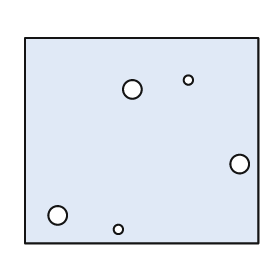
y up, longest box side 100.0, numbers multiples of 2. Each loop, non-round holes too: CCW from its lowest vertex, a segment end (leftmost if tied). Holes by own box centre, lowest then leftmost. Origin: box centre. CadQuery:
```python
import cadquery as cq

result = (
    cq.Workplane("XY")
    .moveTo(-50.0, -44.0)
    .lineTo(50.0, -44.0)
    .lineTo(50.0, 44.0)
    .lineTo(-50.0, 44.0)
    .close()
    .moveTo(-10.0, -38.0)
    .circle(2.0)
    .moveTo(-36.0, -32.0)
    .circle(4.0)
    .moveTo(42.0, -10.0)
    .circle(4.0)
    .moveTo(-4.0, 22.0)
    .circle(4.0)
    .moveTo(20.0, 26.0)
    .circle(2.0)
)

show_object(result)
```